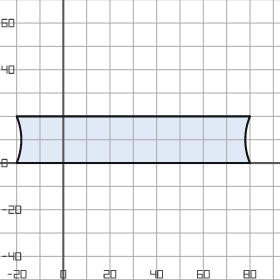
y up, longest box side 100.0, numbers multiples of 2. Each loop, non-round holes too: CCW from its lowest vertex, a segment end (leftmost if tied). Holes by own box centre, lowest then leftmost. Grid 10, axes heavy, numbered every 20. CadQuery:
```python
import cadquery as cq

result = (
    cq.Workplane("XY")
    .moveTo(-20.0, 0.0)
    .lineTo(80.0, 0.0)
    .threePointArc((78.0, 10.0), (80.0, 20.0))
    .lineTo(-20.0, 20.0)
    .threePointArc((-18.0, 10.0), (-20.0, 0.0))
    .close()
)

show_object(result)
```